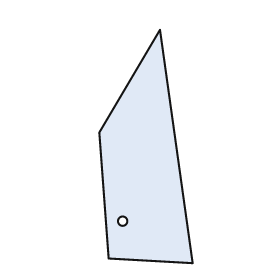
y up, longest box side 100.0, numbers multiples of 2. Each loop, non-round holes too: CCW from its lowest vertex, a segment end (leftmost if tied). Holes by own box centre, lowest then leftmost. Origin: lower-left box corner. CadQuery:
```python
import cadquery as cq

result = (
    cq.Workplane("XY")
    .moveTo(40.0, 0.0)
    .lineTo(26.0, 100.0)
    .lineTo(0.0, 56.0)
    .lineTo(4.0, 2.0)
    .close()
    .moveTo(10.0, 18.0)
    .circle(2.0)
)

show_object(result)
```